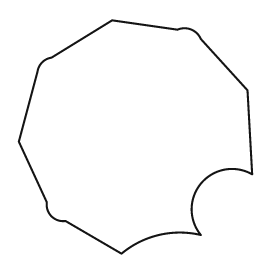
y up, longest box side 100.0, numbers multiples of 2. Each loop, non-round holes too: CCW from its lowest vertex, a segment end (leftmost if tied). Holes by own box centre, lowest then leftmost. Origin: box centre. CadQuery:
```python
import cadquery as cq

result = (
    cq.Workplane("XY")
    .moveTo(-6.0, -50.0)
    .threePointArc((10.0, -42.0), (28.0, -42.0))
    .threePointArc((28.0, -20.0), (50.0, -16.0))
    .lineTo(48.0, 20.0)
    .lineTo(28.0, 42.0)
    .threePointArc((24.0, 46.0), (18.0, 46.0))
    .lineTo(-10.0, 50.0)
    .lineTo(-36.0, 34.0)
    .threePointArc((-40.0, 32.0), (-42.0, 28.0))
    .lineTo(-50.0, -2.0)
    .lineTo(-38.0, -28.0)
    .threePointArc((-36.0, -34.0), (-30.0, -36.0))
    .close()
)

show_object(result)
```